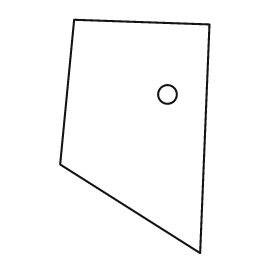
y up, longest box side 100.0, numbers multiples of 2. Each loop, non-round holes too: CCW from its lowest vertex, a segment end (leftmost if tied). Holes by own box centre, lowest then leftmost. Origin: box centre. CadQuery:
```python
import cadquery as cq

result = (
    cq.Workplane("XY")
    .moveTo(28.0, -50.0)
    .lineTo(32.0, 48.0)
    .lineTo(-26.0, 50.0)
    .lineTo(-32.0, -12.0)
    .close()
    .moveTo(14.0, 18.0)
    .circle(4.0)
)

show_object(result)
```